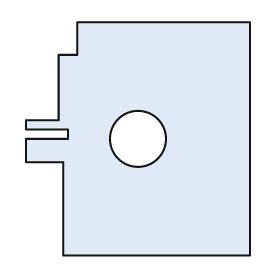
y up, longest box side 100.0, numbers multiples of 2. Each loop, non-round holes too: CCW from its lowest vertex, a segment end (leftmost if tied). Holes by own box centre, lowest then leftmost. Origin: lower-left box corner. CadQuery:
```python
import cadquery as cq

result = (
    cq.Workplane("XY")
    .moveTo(16.0, 0.0)
    .lineTo(96.0, 0.0)
    .lineTo(96.0, 100.0)
    .lineTo(22.0, 100.0)
    .lineTo(22.0, 86.0)
    .lineTo(14.0, 86.0)
    .lineTo(14.0, 58.0)
    .lineTo(0.0, 58.0)
    .lineTo(0.0, 54.0)
    .lineTo(18.0, 54.0)
    .lineTo(18.0, 50.0)
    .lineTo(0.0, 50.0)
    .lineTo(0.0, 40.0)
    .lineTo(16.0, 40.0)
    .close()
    .moveTo(48.0, 50.0)
    .circle(12.0)
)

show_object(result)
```